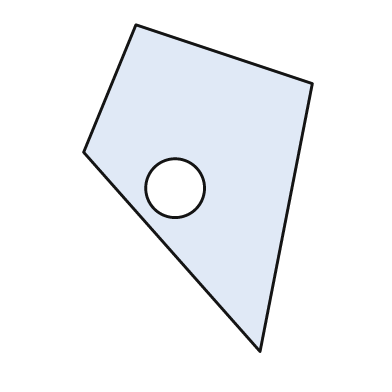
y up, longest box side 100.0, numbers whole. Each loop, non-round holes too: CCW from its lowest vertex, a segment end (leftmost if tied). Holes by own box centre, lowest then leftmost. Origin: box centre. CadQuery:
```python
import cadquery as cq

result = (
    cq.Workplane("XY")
    .moveTo(19.0, -50.0)
    .lineTo(35.0, 32.0)
    .lineTo(-19.0, 50.0)
    .lineTo(-35.0, 11.0)
    .close()
    .moveTo(-7.0, 0.0)
    .circle(9.0)
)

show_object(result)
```